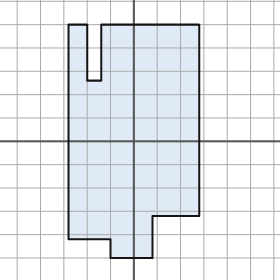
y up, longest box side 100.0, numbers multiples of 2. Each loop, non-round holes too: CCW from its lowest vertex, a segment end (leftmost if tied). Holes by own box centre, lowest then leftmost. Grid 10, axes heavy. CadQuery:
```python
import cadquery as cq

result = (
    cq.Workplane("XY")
    .moveTo(-10.0, -50.0)
    .lineTo(8.0, -50.0)
    .lineTo(8.0, -32.0)
    .lineTo(28.0, -32.0)
    .lineTo(28.0, 50.0)
    .lineTo(-14.0, 50.0)
    .lineTo(-14.0, 26.0)
    .lineTo(-20.0, 26.0)
    .lineTo(-20.0, 50.0)
    .lineTo(-28.0, 50.0)
    .lineTo(-28.0, -42.0)
    .lineTo(-10.0, -42.0)
    .close()
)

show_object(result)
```